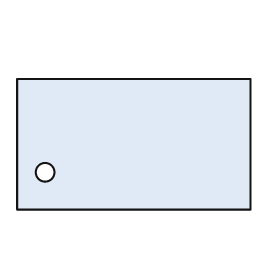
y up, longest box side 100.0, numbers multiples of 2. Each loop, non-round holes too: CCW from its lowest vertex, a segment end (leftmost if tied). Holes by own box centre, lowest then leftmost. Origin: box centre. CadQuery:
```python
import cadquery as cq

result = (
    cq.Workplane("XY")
    .moveTo(-50.0, -28.0)
    .lineTo(50.0, -28.0)
    .lineTo(50.0, 28.0)
    .lineTo(-50.0, 28.0)
    .close()
    .moveTo(-38.0, -12.0)
    .circle(4.0)
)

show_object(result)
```